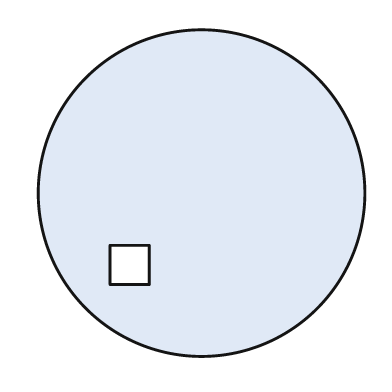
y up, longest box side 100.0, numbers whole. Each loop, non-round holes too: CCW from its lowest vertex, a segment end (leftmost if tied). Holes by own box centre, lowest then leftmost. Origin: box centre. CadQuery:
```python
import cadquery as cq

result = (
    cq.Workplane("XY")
    .moveTo(0.0, 0.0)
    .circle(50.0)
    .moveTo(-28.0, -28.0)
    .lineTo(-16.0, -28.0)
    .lineTo(-16.0, -16.0)
    .lineTo(-28.0, -16.0)
    .close()
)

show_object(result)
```